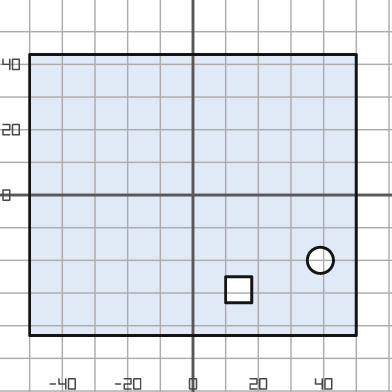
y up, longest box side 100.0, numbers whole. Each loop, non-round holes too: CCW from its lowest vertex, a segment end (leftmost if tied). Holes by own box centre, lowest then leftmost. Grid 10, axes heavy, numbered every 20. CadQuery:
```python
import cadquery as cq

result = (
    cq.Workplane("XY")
    .moveTo(-50.0, -43.0)
    .lineTo(50.0, -43.0)
    .lineTo(50.0, 43.0)
    .lineTo(-50.0, 43.0)
    .close()
    .moveTo(10.0, -33.0)
    .lineTo(18.0, -33.0)
    .lineTo(18.0, -25.0)
    .lineTo(10.0, -25.0)
    .close()
    .moveTo(39.0, -20.0)
    .circle(4.0)
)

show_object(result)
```